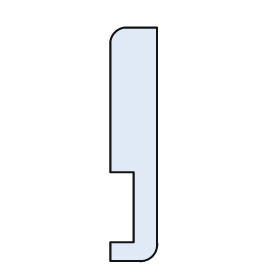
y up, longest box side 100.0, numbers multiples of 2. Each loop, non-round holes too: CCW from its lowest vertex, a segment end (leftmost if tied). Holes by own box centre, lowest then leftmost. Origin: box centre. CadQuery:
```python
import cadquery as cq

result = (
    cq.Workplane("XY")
    .moveTo(-10.0, -50.0)
    .lineTo(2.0, -50.0)
    .threePointArc((8.0, -48.0), (10.0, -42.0))
    .lineTo(10.0, 50.0)
    .lineTo(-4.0, 50.0)
    .threePointArc((-8.0, 48.0), (-10.0, 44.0))
    .lineTo(-10.0, -12.0)
    .lineTo(0.0, -12.0)
    .lineTo(0.0, -42.0)
    .lineTo(-10.0, -42.0)
    .close()
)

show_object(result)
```